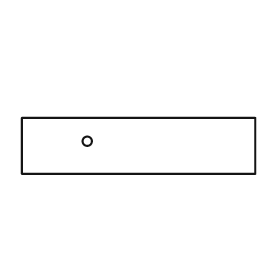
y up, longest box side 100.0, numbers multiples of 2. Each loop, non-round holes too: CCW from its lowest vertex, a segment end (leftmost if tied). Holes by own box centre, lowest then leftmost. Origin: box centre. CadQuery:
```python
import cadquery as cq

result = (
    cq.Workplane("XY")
    .moveTo(-50.0, -12.0)
    .lineTo(50.0, -12.0)
    .lineTo(50.0, 12.0)
    .lineTo(-50.0, 12.0)
    .close()
    .moveTo(-22.0, 2.0)
    .circle(2.0)
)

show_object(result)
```